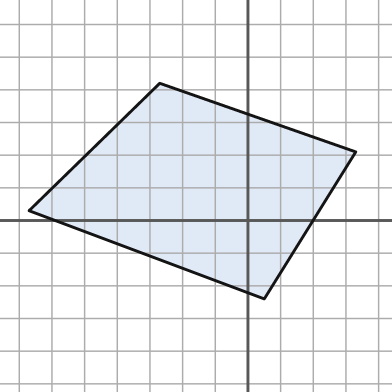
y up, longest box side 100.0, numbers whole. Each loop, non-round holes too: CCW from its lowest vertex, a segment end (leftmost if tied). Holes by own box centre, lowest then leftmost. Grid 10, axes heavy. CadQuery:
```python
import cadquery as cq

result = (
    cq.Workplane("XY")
    .moveTo(5.0, -24.0)
    .lineTo(33.0, 21.0)
    .lineTo(-27.0, 42.0)
    .lineTo(-67.0, 3.0)
    .close()
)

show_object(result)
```